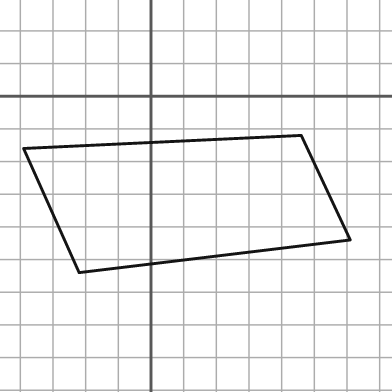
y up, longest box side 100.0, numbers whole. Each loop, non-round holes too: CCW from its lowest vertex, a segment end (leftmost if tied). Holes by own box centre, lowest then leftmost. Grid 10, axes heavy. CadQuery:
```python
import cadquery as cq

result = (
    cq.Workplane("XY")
    .moveTo(-22.0, -54.0)
    .lineTo(61.0, -44.0)
    .lineTo(46.0, -12.0)
    .lineTo(-39.0, -16.0)
    .close()
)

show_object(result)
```